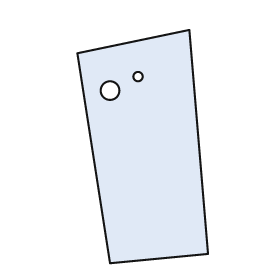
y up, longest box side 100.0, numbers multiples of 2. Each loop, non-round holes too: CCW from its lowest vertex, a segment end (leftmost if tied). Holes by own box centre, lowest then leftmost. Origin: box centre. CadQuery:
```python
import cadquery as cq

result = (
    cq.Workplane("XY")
    .moveTo(-14.0, -50.0)
    .lineTo(28.0, -46.0)
    .lineTo(20.0, 50.0)
    .lineTo(-28.0, 40.0)
    .close()
    .moveTo(-14.0, 24.0)
    .circle(4.0)
    .moveTo(-2.0, 30.0)
    .circle(2.0)
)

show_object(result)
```